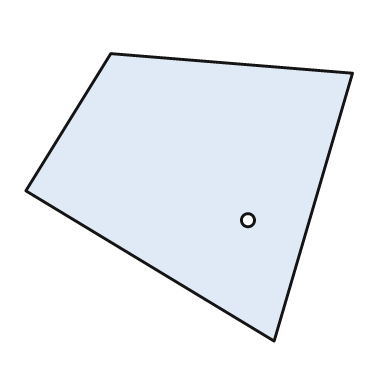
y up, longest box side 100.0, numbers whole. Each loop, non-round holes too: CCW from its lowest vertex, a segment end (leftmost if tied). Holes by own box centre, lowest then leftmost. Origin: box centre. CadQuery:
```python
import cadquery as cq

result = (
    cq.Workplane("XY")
    .moveTo(26.0, -44.0)
    .lineTo(50.0, 38.0)
    .lineTo(-24.0, 44.0)
    .lineTo(-50.0, 2.0)
    .close()
    .moveTo(18.0, -7.0)
    .circle(2.0)
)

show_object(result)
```